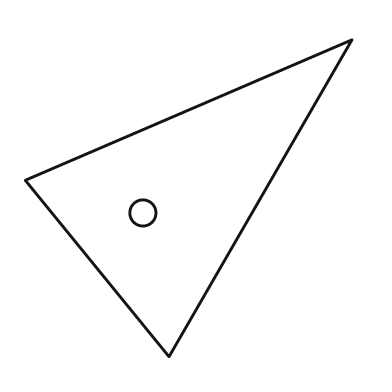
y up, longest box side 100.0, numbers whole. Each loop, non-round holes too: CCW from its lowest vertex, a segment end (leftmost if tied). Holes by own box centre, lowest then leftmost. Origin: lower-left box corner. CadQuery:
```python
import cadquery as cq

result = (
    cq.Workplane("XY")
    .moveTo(44.0, 0.0)
    .lineTo(100.0, 97.0)
    .lineTo(0.0, 54.0)
    .close()
    .moveTo(36.0, 44.0)
    .circle(4.0)
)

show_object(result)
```